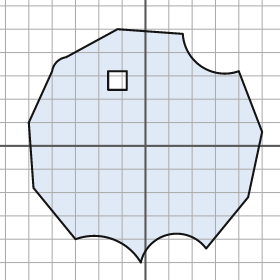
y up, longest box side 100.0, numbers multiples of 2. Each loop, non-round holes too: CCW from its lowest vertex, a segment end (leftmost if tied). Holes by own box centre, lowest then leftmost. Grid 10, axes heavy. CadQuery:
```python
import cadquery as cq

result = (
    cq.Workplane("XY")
    .moveTo(-2.0, -50.0)
    .threePointArc((10.0, -38.0), (26.0, -44.0))
    .lineTo(44.0, -22.0)
    .lineTo(50.0, 6.0)
    .lineTo(40.0, 32.0)
    .threePointArc((24.0, 34.0), (16.0, 48.0))
    .lineTo(-12.0, 50.0)
    .lineTo(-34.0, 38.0)
    .threePointArc((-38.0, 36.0), (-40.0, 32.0))
    .lineTo(-50.0, 10.0)
    .lineTo(-48.0, -18.0)
    .lineTo(-30.0, -40.0)
    .threePointArc((-14.0, -40.0), (-2.0, -50.0))
    .close()
    .moveTo(-16.0, 24.0)
    .lineTo(-8.0, 24.0)
    .lineTo(-8.0, 32.0)
    .lineTo(-16.0, 32.0)
    .close()
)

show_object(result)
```